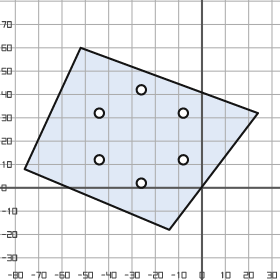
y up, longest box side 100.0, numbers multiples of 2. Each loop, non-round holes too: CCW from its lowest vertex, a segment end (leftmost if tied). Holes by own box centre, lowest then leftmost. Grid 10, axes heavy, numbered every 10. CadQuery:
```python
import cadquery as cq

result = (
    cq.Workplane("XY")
    .moveTo(-14.0, -18.0)
    .lineTo(24.0, 32.0)
    .lineTo(-52.0, 60.0)
    .lineTo(-76.0, 8.0)
    .close()
    .moveTo(-26.0, 2.0)
    .circle(2.0)
    .moveTo(-44.0, 12.0)
    .circle(2.0)
    .moveTo(-8.0, 12.0)
    .circle(2.0)
    .moveTo(-44.0, 32.0)
    .circle(2.0)
    .moveTo(-8.0, 32.0)
    .circle(2.0)
    .moveTo(-26.0, 42.0)
    .circle(2.0)
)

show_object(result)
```